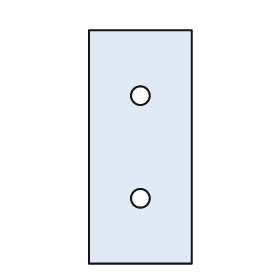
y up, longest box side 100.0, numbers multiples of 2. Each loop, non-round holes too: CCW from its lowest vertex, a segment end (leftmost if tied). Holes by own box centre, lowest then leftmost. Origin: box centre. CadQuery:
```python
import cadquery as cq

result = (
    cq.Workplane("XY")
    .moveTo(-22.0, -50.0)
    .lineTo(22.0, -50.0)
    .lineTo(22.0, 50.0)
    .lineTo(-22.0, 50.0)
    .close()
    .moveTo(0.0, -22.0)
    .circle(4.0)
    .moveTo(0.0, 22.0)
    .circle(4.0)
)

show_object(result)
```